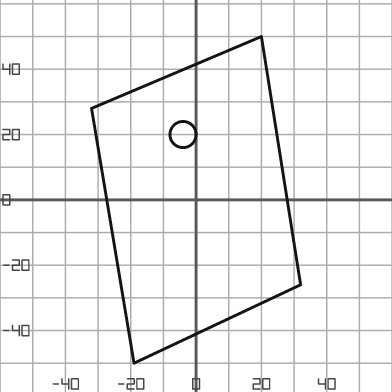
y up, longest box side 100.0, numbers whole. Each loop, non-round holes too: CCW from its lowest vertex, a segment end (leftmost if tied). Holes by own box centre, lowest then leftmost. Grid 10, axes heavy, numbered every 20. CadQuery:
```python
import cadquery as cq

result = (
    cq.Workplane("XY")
    .moveTo(-19.0, -50.0)
    .lineTo(32.0, -26.0)
    .lineTo(20.0, 50.0)
    .lineTo(-32.0, 28.0)
    .close()
    .moveTo(-4.0, 20.0)
    .circle(4.0)
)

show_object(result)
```